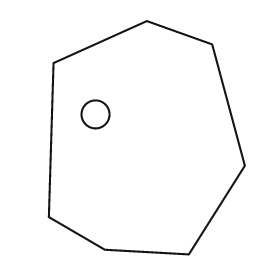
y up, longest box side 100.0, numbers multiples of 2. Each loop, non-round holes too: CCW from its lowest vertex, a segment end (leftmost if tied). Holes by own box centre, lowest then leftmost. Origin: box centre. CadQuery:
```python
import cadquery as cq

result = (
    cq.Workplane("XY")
    .moveTo(18.0, -50.0)
    .lineTo(42.0, -12.0)
    .lineTo(28.0, 40.0)
    .lineTo(0.0, 50.0)
    .lineTo(-40.0, 32.0)
    .lineTo(-42.0, -34.0)
    .lineTo(-18.0, -48.0)
    .close()
    .moveTo(-22.0, 10.0)
    .circle(6.0)
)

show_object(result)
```